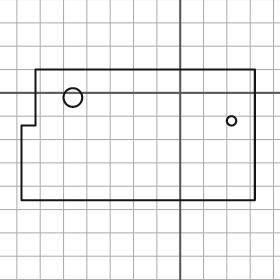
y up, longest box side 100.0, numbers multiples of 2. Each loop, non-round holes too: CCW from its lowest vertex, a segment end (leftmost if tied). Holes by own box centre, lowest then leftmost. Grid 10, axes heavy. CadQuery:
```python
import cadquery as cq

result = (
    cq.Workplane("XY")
    .moveTo(-68.0, -46.0)
    .lineTo(32.0, -46.0)
    .lineTo(32.0, 10.0)
    .lineTo(-62.0, 10.0)
    .lineTo(-62.0, -14.0)
    .lineTo(-68.0, -14.0)
    .close()
    .moveTo(22.0, -12.0)
    .circle(2.0)
    .moveTo(-46.0, -2.0)
    .circle(4.0)
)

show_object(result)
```